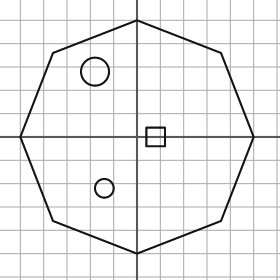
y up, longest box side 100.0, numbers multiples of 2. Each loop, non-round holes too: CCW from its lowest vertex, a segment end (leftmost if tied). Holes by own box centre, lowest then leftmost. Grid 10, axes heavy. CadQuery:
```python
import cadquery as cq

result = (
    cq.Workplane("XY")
    .moveTo(0.0, -50.0)
    .lineTo(36.0, -36.0)
    .lineTo(50.0, 0.0)
    .lineTo(36.0, 36.0)
    .lineTo(0.0, 50.0)
    .lineTo(-36.0, 36.0)
    .lineTo(-50.0, 0.0)
    .lineTo(-36.0, -36.0)
    .close()
    .moveTo(-14.0, -22.0)
    .circle(4.0)
    .moveTo(4.0, -4.0)
    .lineTo(12.0, -4.0)
    .lineTo(12.0, 4.0)
    .lineTo(4.0, 4.0)
    .close()
    .moveTo(-18.0, 28.0)
    .circle(6.0)
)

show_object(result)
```